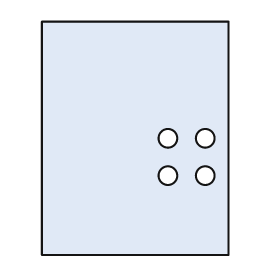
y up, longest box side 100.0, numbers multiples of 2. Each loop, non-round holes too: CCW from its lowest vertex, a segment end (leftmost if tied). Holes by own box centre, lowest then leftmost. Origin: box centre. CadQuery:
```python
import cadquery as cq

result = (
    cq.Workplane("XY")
    .moveTo(-40.0, -50.0)
    .lineTo(40.0, -50.0)
    .lineTo(40.0, 50.0)
    .lineTo(-40.0, 50.0)
    .close()
    .moveTo(14.0, -16.0)
    .circle(4.0)
    .moveTo(30.0, -16.0)
    .circle(4.0)
    .moveTo(14.0, 0.0)
    .circle(4.0)
    .moveTo(30.0, 0.0)
    .circle(4.0)
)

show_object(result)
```